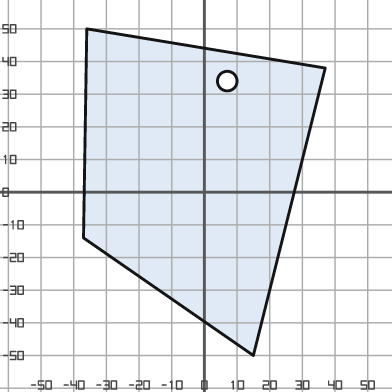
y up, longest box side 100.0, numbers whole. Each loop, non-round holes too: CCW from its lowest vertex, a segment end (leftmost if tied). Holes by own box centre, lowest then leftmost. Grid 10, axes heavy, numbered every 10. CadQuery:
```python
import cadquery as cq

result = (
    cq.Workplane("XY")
    .moveTo(15.0, -50.0)
    .lineTo(37.0, 38.0)
    .lineTo(-36.0, 50.0)
    .lineTo(-37.0, -14.0)
    .close()
    .moveTo(7.0, 34.0)
    .circle(3.0)
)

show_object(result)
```